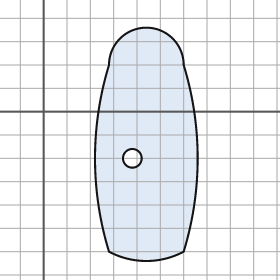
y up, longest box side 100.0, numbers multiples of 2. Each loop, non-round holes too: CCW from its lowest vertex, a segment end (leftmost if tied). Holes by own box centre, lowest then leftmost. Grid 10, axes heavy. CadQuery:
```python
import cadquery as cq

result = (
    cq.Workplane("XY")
    .moveTo(28.0, -60.0)
    .threePointArc((44.0, -64.0), (60.0, -60.0))
    .threePointArc((66.0, -20.0), (60.0, 20.0))
    .threePointArc((44.0, 36.0), (28.0, 20.0))
    .threePointArc((22.0, -20.0), (28.0, -60.0))
    .close()
    .moveTo(38.0, -20.0)
    .circle(4.0)
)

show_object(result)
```